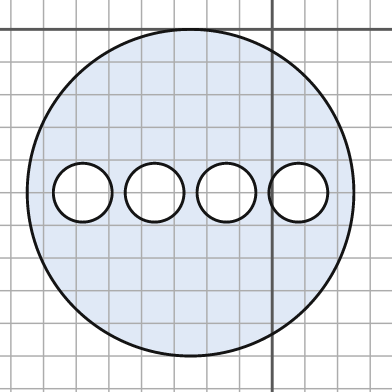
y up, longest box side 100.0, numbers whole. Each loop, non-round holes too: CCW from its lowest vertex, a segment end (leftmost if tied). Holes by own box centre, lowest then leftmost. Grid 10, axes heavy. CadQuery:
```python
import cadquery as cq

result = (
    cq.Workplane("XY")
    .moveTo(-25.0, -50.0)
    .circle(50.0)
    .moveTo(-58.0, -50.0)
    .circle(9.0)
    .moveTo(-36.0, -50.0)
    .circle(9.0)
    .moveTo(-14.0, -50.0)
    .circle(9.0)
    .moveTo(8.0, -50.0)
    .circle(9.0)
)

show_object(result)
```